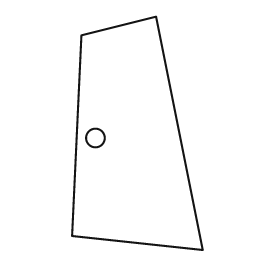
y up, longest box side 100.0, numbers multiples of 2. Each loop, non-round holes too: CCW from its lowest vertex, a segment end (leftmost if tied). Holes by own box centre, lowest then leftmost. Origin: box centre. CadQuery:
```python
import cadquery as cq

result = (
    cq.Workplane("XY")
    .moveTo(28.0, -50.0)
    .lineTo(8.0, 50.0)
    .lineTo(-24.0, 42.0)
    .lineTo(-28.0, -44.0)
    .close()
    .moveTo(-18.0, -2.0)
    .circle(4.0)
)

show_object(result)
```